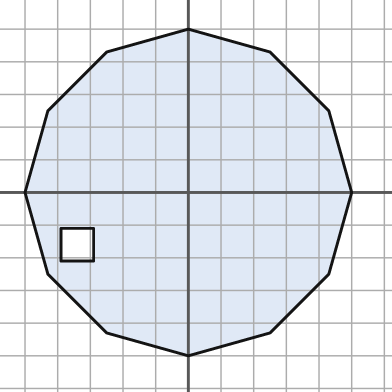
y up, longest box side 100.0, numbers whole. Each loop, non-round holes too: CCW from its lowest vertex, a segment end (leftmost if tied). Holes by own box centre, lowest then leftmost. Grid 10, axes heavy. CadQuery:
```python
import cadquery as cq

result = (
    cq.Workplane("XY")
    .moveTo(0.0, -50.0)
    .lineTo(25.0, -43.0)
    .lineTo(43.0, -25.0)
    .lineTo(50.0, 0.0)
    .lineTo(43.0, 25.0)
    .lineTo(25.0, 43.0)
    .lineTo(0.0, 50.0)
    .lineTo(-25.0, 43.0)
    .lineTo(-43.0, 25.0)
    .lineTo(-50.0, 0.0)
    .lineTo(-43.0, -25.0)
    .lineTo(-25.0, -43.0)
    .close()
    .moveTo(-39.0, -21.0)
    .lineTo(-29.0, -21.0)
    .lineTo(-29.0, -11.0)
    .lineTo(-39.0, -11.0)
    .close()
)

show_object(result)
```